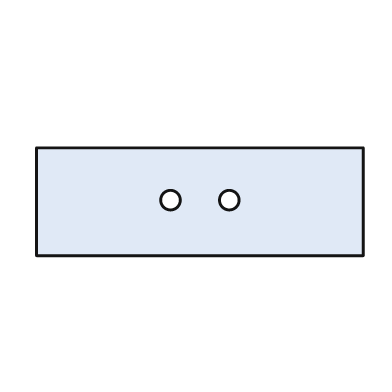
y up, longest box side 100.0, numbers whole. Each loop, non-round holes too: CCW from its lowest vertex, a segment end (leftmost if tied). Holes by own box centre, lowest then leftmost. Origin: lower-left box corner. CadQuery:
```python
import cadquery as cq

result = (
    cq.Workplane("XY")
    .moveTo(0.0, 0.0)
    .lineTo(100.0, 0.0)
    .lineTo(100.0, 33.0)
    .lineTo(0.0, 33.0)
    .close()
    .moveTo(41.0, 17.0)
    .circle(3.0)
    .moveTo(59.0, 17.0)
    .circle(3.0)
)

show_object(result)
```